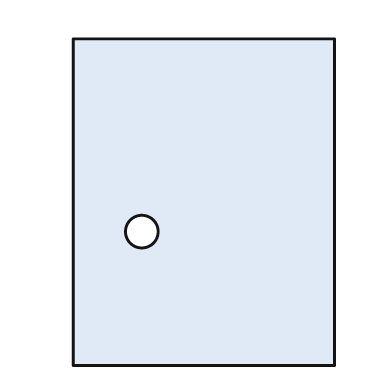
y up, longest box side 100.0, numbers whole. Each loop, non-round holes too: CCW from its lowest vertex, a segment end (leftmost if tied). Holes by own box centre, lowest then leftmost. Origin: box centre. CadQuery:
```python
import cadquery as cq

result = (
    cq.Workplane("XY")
    .moveTo(-40.0, -50.0)
    .lineTo(40.0, -50.0)
    .lineTo(40.0, 50.0)
    .lineTo(-40.0, 50.0)
    .close()
    .moveTo(-19.0, -9.0)
    .circle(5.0)
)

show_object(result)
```